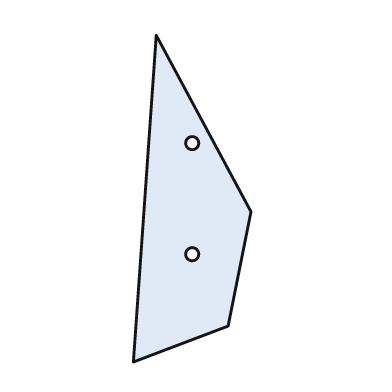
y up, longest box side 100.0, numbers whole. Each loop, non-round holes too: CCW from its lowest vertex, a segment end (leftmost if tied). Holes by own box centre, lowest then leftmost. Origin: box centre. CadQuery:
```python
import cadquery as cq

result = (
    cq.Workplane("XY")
    .moveTo(-18.0, -50.0)
    .lineTo(11.0, -39.0)
    .lineTo(18.0, -4.0)
    .lineTo(-11.0, 50.0)
    .close()
    .moveTo(0.0, -17.0)
    .circle(2.0)
    .moveTo(0.0, 17.0)
    .circle(2.0)
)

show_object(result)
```